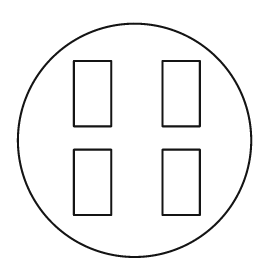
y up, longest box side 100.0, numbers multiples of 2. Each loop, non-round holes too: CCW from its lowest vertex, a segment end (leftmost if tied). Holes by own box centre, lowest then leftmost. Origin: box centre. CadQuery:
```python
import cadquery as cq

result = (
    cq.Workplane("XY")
    .moveTo(0.0, 0.0)
    .circle(50.0)
    .moveTo(-26.0, -32.0)
    .lineTo(-10.0, -32.0)
    .lineTo(-10.0, -4.0)
    .lineTo(-26.0, -4.0)
    .close()
    .moveTo(12.0, -32.0)
    .lineTo(28.0, -32.0)
    .lineTo(28.0, -4.0)
    .lineTo(12.0, -4.0)
    .close()
    .moveTo(-26.0, 6.0)
    .lineTo(-10.0, 6.0)
    .lineTo(-10.0, 34.0)
    .lineTo(-26.0, 34.0)
    .close()
    .moveTo(12.0, 6.0)
    .lineTo(28.0, 6.0)
    .lineTo(28.0, 34.0)
    .lineTo(12.0, 34.0)
    .close()
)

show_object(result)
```